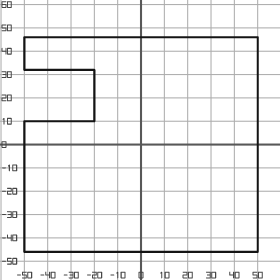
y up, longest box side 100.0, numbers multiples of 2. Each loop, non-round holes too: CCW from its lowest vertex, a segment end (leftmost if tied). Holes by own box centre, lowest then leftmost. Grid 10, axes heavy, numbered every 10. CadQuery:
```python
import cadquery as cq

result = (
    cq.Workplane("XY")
    .moveTo(-50.0, -46.0)
    .lineTo(50.0, -46.0)
    .lineTo(50.0, 46.0)
    .lineTo(-50.0, 46.0)
    .lineTo(-50.0, 32.0)
    .lineTo(-20.0, 32.0)
    .lineTo(-20.0, 10.0)
    .lineTo(-50.0, 10.0)
    .close()
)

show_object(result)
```